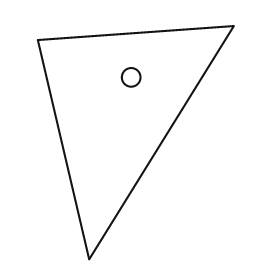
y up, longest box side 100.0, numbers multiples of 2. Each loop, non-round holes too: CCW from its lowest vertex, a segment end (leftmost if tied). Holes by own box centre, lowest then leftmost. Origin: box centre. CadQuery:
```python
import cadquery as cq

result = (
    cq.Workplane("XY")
    .moveTo(-20.0, -50.0)
    .lineTo(42.0, 50.0)
    .lineTo(-42.0, 44.0)
    .close()
    .moveTo(-2.0, 28.0)
    .circle(4.0)
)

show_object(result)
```